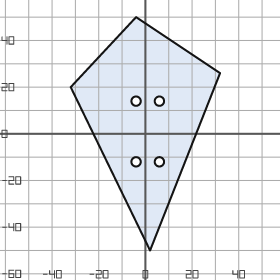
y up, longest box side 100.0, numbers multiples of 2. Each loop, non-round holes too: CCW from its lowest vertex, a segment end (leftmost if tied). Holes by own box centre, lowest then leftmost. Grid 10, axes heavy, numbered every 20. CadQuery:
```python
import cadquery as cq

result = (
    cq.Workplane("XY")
    .moveTo(2.0, -50.0)
    .lineTo(32.0, 26.0)
    .lineTo(-4.0, 50.0)
    .lineTo(-32.0, 20.0)
    .close()
    .moveTo(-4.0, -12.0)
    .circle(2.0)
    .moveTo(6.0, -12.0)
    .circle(2.0)
    .moveTo(-4.0, 14.0)
    .circle(2.0)
    .moveTo(6.0, 14.0)
    .circle(2.0)
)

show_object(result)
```